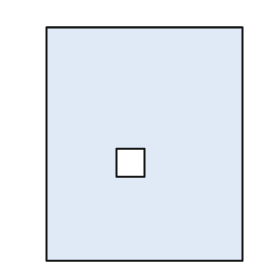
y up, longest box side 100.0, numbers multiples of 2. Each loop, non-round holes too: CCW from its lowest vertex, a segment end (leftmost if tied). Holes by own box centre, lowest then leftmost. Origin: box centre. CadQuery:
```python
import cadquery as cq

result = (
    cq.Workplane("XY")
    .moveTo(-42.0, -50.0)
    .lineTo(42.0, -50.0)
    .lineTo(42.0, 50.0)
    .lineTo(-42.0, 50.0)
    .close()
    .moveTo(-12.0, -14.0)
    .lineTo(0.0, -14.0)
    .lineTo(0.0, -2.0)
    .lineTo(-12.0, -2.0)
    .close()
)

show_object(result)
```